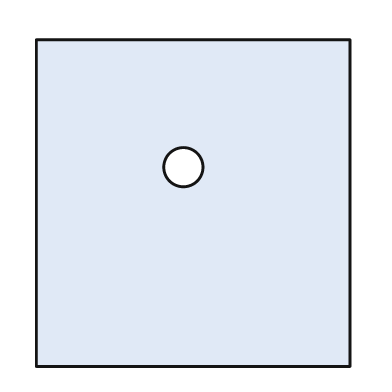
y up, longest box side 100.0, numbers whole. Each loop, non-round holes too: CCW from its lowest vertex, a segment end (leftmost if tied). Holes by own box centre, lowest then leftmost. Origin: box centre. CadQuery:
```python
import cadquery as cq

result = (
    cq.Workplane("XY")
    .moveTo(-48.0, -50.0)
    .lineTo(48.0, -50.0)
    .lineTo(48.0, 50.0)
    .lineTo(-48.0, 50.0)
    .close()
    .moveTo(-3.0, 11.0)
    .circle(6.0)
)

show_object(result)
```